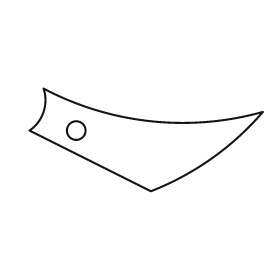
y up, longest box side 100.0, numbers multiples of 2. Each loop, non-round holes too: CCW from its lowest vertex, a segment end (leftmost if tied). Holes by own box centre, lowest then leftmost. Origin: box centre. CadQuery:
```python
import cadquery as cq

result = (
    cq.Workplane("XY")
    .moveTo(2.0, -22.0)
    .threePointArc((28.0, -8.0), (50.0, 12.0))
    .threePointArc((2.0, 8.0), (-44.0, 22.0))
    .threePointArc((-44.0, 12.0), (-50.0, 4.0))
    .close()
    .moveTo(-30.0, 4.0)
    .circle(4.0)
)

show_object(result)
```